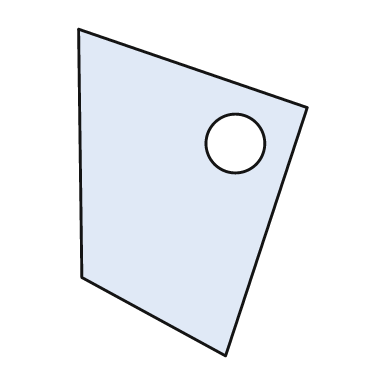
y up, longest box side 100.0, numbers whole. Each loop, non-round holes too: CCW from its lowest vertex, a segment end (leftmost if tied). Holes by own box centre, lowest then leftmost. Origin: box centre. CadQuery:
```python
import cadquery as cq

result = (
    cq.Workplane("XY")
    .moveTo(10.0, -50.0)
    .lineTo(35.0, 26.0)
    .lineTo(-35.0, 50.0)
    .lineTo(-34.0, -26.0)
    .close()
    .moveTo(13.0, 15.0)
    .circle(9.0)
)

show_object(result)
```